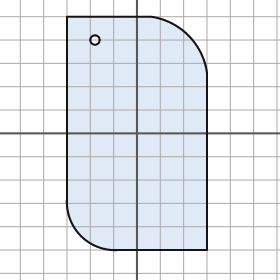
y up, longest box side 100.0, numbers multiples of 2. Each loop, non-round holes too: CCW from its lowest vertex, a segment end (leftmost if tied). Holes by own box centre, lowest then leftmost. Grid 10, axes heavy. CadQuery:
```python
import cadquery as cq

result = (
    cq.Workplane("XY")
    .moveTo(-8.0, -50.0)
    .lineTo(30.0, -50.0)
    .lineTo(30.0, 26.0)
    .threePointArc((22.0, 42.0), (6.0, 50.0))
    .lineTo(-30.0, 50.0)
    .lineTo(-30.0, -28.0)
    .threePointArc((-24.0, -44.0), (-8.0, -50.0))
    .close()
    .moveTo(-18.0, 40.0)
    .circle(2.0)
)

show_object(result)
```